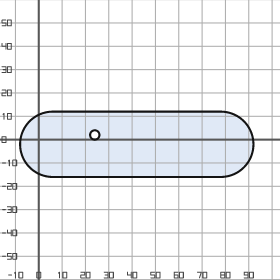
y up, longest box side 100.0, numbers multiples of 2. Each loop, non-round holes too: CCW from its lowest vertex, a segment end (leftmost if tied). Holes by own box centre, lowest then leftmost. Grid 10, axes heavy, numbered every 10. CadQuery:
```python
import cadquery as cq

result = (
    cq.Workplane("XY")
    .moveTo(6.0, -16.0)
    .lineTo(78.0, -16.0)
    .threePointArc((92.0, -2.0), (78.0, 12.0))
    .lineTo(6.0, 12.0)
    .threePointArc((-8.0, -2.0), (6.0, -16.0))
    .close()
    .moveTo(24.0, 2.0)
    .circle(2.0)
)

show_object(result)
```